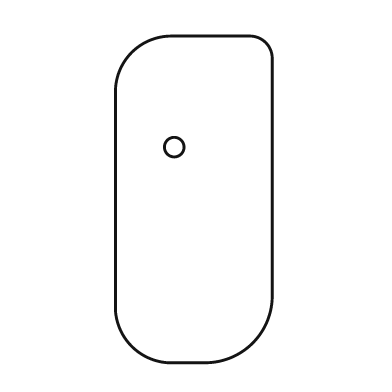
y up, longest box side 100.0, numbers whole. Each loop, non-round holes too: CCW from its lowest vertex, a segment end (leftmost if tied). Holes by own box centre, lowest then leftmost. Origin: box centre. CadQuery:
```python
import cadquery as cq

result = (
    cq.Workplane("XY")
    .moveTo(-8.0, -50.0)
    .lineTo(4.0, -50.0)
    .threePointArc((18.0, -44.0), (24.0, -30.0))
    .lineTo(24.0, 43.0)
    .threePointArc((22.0, 48.0), (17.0, 50.0))
    .lineTo(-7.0, 50.0)
    .threePointArc((-19.0, 45.0), (-24.0, 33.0))
    .lineTo(-24.0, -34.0)
    .threePointArc((-19.0, -45.0), (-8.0, -50.0))
    .close()
    .moveTo(-6.0, 16.0)
    .circle(3.0)
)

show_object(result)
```